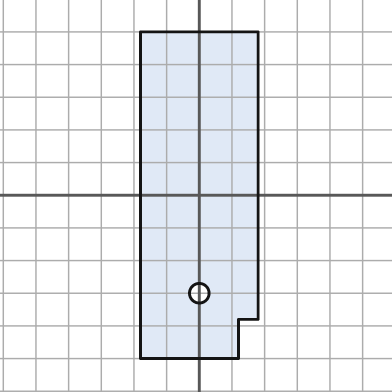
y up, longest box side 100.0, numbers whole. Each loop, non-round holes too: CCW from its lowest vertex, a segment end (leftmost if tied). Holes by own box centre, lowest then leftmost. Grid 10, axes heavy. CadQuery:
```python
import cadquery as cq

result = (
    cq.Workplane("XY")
    .moveTo(-18.0, -50.0)
    .lineTo(12.0, -50.0)
    .lineTo(12.0, -38.0)
    .lineTo(18.0, -38.0)
    .lineTo(18.0, 50.0)
    .lineTo(-18.0, 50.0)
    .close()
    .moveTo(0.0, -30.0)
    .circle(3.0)
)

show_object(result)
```